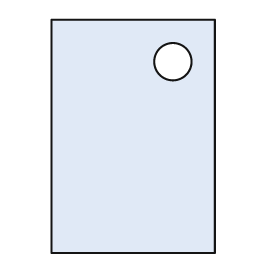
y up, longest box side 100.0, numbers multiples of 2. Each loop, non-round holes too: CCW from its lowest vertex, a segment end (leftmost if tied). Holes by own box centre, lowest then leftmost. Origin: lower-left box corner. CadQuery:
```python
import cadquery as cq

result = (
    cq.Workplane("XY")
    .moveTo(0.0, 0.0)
    .lineTo(70.0, 0.0)
    .lineTo(70.0, 100.0)
    .lineTo(0.0, 100.0)
    .close()
    .moveTo(52.0, 82.0)
    .circle(8.0)
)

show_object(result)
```